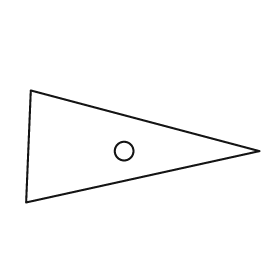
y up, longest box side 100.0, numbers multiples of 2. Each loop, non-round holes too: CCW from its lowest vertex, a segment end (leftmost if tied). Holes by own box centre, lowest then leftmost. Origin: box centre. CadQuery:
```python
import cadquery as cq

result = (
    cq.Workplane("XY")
    .moveTo(-50.0, -24.0)
    .lineTo(50.0, -2.0)
    .lineTo(-48.0, 24.0)
    .close()
    .moveTo(-8.0, -2.0)
    .circle(4.0)
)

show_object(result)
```